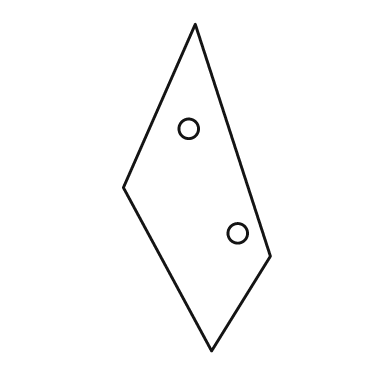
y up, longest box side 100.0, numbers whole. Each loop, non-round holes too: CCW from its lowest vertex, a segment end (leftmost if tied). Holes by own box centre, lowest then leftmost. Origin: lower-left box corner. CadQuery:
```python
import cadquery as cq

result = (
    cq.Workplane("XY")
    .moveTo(27.0, 0.0)
    .lineTo(45.0, 29.0)
    .lineTo(22.0, 100.0)
    .lineTo(0.0, 50.0)
    .close()
    .moveTo(35.0, 36.0)
    .circle(3.0)
    .moveTo(20.0, 68.0)
    .circle(3.0)
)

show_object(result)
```